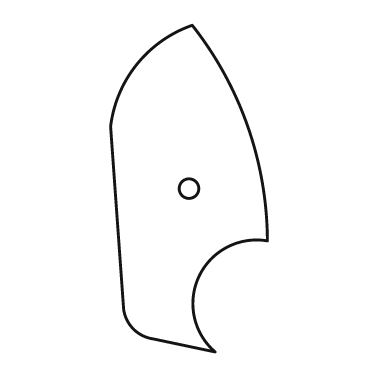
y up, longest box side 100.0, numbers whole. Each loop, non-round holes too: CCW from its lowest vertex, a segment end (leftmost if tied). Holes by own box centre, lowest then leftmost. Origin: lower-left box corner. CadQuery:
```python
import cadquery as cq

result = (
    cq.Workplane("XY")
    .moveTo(32.0, 0.0)
    .threePointArc((27.0, 23.0), (48.0, 34.0))
    .threePointArc((42.0, 69.0), (25.0, 100.0))
    .threePointArc((8.0, 88.0), (0.0, 69.0))
    .lineTo(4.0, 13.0)
    .threePointArc((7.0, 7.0), (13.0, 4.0))
    .close()
    .moveTo(24.0, 50.0)
    .circle(3.0)
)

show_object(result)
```